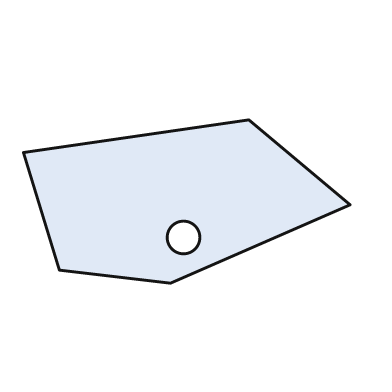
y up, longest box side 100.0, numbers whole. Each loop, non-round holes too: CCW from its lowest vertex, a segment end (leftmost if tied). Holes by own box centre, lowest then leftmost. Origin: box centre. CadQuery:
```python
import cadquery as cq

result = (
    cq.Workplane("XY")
    .moveTo(-5.0, -25.0)
    .lineTo(50.0, -1.0)
    .lineTo(19.0, 25.0)
    .lineTo(-50.0, 15.0)
    .lineTo(-39.0, -21.0)
    .close()
    .moveTo(-1.0, -11.0)
    .circle(5.0)
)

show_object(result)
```